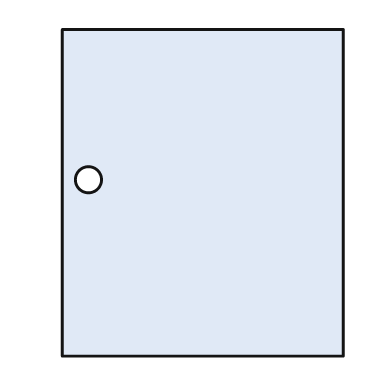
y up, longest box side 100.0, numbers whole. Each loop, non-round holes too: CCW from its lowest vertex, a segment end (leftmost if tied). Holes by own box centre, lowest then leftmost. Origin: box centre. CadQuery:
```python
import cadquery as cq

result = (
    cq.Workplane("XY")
    .moveTo(-43.0, -50.0)
    .lineTo(43.0, -50.0)
    .lineTo(43.0, 50.0)
    .lineTo(-43.0, 50.0)
    .close()
    .moveTo(-35.0, 4.0)
    .circle(4.0)
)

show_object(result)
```